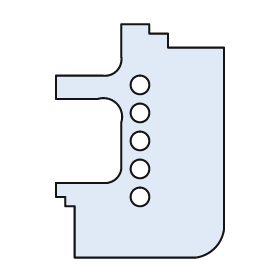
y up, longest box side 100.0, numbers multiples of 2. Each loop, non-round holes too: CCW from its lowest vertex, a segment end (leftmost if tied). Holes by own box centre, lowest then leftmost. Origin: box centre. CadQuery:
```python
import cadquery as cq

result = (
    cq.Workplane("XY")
    .moveTo(-28.0, -50.0)
    .lineTo(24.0, -50.0)
    .threePointArc((32.0, -46.0), (36.0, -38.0))
    .lineTo(36.0, 40.0)
    .lineTo(12.0, 40.0)
    .lineTo(12.0, 46.0)
    .lineTo(4.0, 46.0)
    .lineTo(4.0, 50.0)
    .lineTo(-8.0, 50.0)
    .lineTo(-8.0, 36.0)
    .threePointArc((-10.0, 30.0), (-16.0, 28.0))
    .lineTo(-36.0, 28.0)
    .lineTo(-36.0, 18.0)
    .lineTo(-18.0, 18.0)
    .threePointArc((-10.0, 16.0), (-8.0, 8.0))
    .lineTo(-8.0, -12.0)
    .threePointArc((-10.0, -16.0), (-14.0, -18.0))
    .lineTo(-36.0, -18.0)
    .lineTo(-36.0, -24.0)
    .lineTo(-32.0, -24.0)
    .lineTo(-32.0, -28.0)
    .lineTo(-28.0, -28.0)
    .close()
    .moveTo(0.0, -24.0)
    .circle(4.0)
    .moveTo(0.0, -12.0)
    .circle(4.0)
    .moveTo(0.0, 0.0)
    .circle(4.0)
    .moveTo(0.0, 12.0)
    .circle(4.0)
    .moveTo(0.0, 24.0)
    .circle(4.0)
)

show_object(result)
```